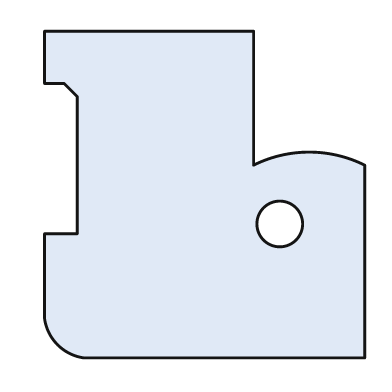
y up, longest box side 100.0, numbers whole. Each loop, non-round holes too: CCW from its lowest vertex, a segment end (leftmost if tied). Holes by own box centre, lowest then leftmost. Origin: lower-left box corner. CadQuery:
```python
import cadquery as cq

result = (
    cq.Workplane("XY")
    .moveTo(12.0, 0.0)
    .lineTo(98.0, 0.0)
    .lineTo(98.0, 59.0)
    .threePointArc((81.0, 63.0), (64.0, 59.0))
    .lineTo(64.0, 100.0)
    .lineTo(0.0, 100.0)
    .lineTo(0.0, 84.0)
    .lineTo(6.0, 84.0)
    .lineTo(10.0, 80.0)
    .lineTo(10.0, 38.0)
    .lineTo(0.0, 38.0)
    .lineTo(0.0, 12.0)
    .threePointArc((4.0, 4.0), (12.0, 0.0))
    .close()
    .moveTo(72.0, 41.0)
    .circle(7.0)
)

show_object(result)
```